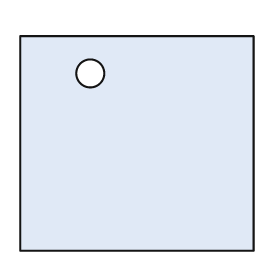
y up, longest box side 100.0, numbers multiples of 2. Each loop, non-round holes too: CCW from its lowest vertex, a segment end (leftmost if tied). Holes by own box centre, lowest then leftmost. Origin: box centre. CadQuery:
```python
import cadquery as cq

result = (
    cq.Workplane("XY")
    .moveTo(-50.0, -46.0)
    .lineTo(50.0, -46.0)
    .lineTo(50.0, 46.0)
    .lineTo(-50.0, 46.0)
    .close()
    .moveTo(-20.0, 30.0)
    .circle(6.0)
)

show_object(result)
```